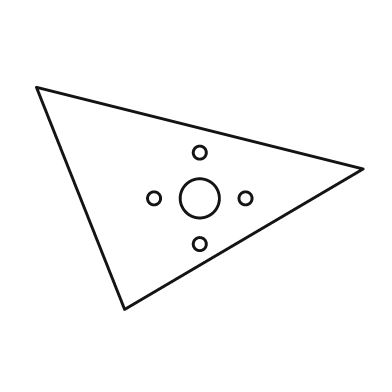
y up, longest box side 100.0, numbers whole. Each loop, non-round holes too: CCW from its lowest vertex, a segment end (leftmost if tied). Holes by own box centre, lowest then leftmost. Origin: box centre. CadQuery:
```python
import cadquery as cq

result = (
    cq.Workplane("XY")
    .moveTo(-23.0, -34.0)
    .lineTo(50.0, 9.0)
    .lineTo(-50.0, 34.0)
    .close()
    .moveTo(0.0, -14.0)
    .circle(2.0)
    .moveTo(-14.0, 0.0)
    .circle(2.0)
    .moveTo(0.0, 0.0)
    .circle(6.0)
    .moveTo(14.0, 0.0)
    .circle(2.0)
    .moveTo(0.0, 14.0)
    .circle(2.0)
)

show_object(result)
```